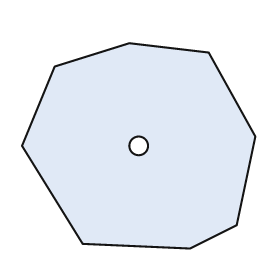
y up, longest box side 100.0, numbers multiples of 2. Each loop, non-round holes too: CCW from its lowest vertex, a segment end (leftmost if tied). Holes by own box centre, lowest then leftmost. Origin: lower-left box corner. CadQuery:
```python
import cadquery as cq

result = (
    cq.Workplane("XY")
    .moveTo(72.0, 0.0)
    .lineTo(92.0, 10.0)
    .lineTo(100.0, 48.0)
    .lineTo(80.0, 84.0)
    .lineTo(46.0, 88.0)
    .lineTo(14.0, 78.0)
    .lineTo(0.0, 44.0)
    .lineTo(26.0, 2.0)
    .close()
    .moveTo(50.0, 44.0)
    .circle(4.0)
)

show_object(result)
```